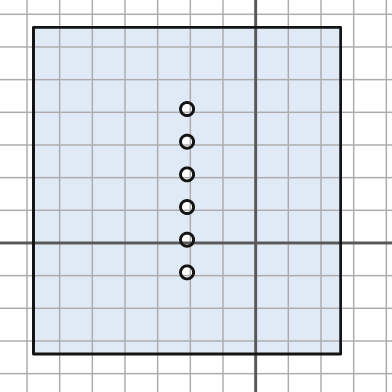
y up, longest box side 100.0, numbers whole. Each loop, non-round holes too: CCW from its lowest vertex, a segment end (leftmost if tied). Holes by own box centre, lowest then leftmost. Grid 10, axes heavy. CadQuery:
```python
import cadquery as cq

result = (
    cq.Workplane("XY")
    .moveTo(-68.0, -34.0)
    .lineTo(26.0, -34.0)
    .lineTo(26.0, 66.0)
    .lineTo(-68.0, 66.0)
    .close()
    .moveTo(-21.0, -9.0)
    .circle(2.0)
    .moveTo(-21.0, 1.0)
    .circle(2.0)
    .moveTo(-21.0, 11.0)
    .circle(2.0)
    .moveTo(-21.0, 21.0)
    .circle(2.0)
    .moveTo(-21.0, 31.0)
    .circle(2.0)
    .moveTo(-21.0, 41.0)
    .circle(2.0)
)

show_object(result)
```